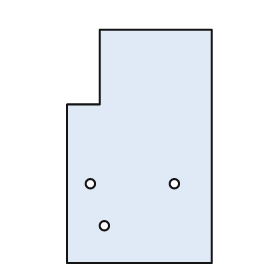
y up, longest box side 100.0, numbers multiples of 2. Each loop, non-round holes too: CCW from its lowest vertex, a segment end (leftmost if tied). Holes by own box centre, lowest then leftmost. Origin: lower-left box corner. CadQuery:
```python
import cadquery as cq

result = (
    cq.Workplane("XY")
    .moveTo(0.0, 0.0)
    .lineTo(62.0, 0.0)
    .lineTo(62.0, 100.0)
    .lineTo(14.0, 100.0)
    .lineTo(14.0, 68.0)
    .lineTo(0.0, 68.0)
    .close()
    .moveTo(16.0, 16.0)
    .circle(2.0)
    .moveTo(10.0, 34.0)
    .circle(2.0)
    .moveTo(46.0, 34.0)
    .circle(2.0)
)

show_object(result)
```